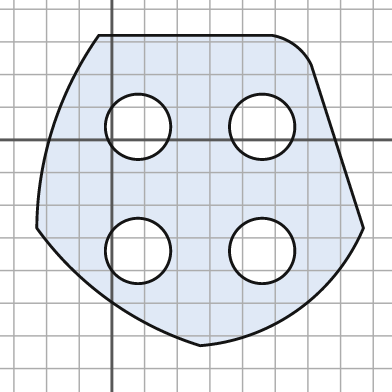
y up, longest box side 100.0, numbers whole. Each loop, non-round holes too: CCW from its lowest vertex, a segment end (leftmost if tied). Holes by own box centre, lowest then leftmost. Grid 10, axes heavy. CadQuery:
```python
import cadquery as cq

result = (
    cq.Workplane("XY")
    .moveTo(27.0, -63.0)
    .threePointArc((57.0, -52.0), (77.0, -27.0))
    .lineTo(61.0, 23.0)
    .threePointArc((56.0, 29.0), (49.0, 32.0))
    .lineTo(-4.0, 32.0)
    .threePointArc((-18.0, 4.0), (-23.0, -27.0))
    .threePointArc((-1.0, -49.0), (27.0, -63.0))
    .close()
    .moveTo(8.0, -34.0)
    .circle(10.0)
    .moveTo(46.0, -34.0)
    .circle(10.0)
    .moveTo(8.0, 4.0)
    .circle(10.0)
    .moveTo(46.0, 4.0)
    .circle(10.0)
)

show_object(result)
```